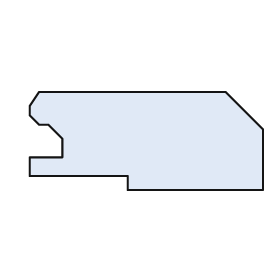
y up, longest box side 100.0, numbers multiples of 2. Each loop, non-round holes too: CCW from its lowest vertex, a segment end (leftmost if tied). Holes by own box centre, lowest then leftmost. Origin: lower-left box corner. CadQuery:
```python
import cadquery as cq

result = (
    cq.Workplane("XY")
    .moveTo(42.0, 0.0)
    .lineTo(100.0, 0.0)
    .lineTo(100.0, 26.0)
    .lineTo(84.0, 42.0)
    .lineTo(4.0, 42.0)
    .lineTo(0.0, 36.0)
    .lineTo(0.0, 32.0)
    .lineTo(4.0, 28.0)
    .lineTo(8.0, 28.0)
    .lineTo(14.0, 22.0)
    .lineTo(14.0, 14.0)
    .lineTo(0.0, 14.0)
    .lineTo(0.0, 6.0)
    .lineTo(42.0, 6.0)
    .close()
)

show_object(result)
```